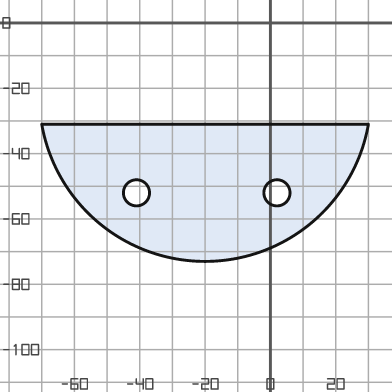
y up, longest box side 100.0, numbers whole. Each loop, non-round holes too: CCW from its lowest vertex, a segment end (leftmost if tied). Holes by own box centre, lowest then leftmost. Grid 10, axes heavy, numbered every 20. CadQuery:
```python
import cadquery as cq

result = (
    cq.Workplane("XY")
    .moveTo(-70.0, -31.0)
    .threePointArc((-20.0, -73.0), (30.0, -31.0))
    .close()
    .moveTo(-41.0, -52.0)
    .circle(4.0)
    .moveTo(2.0, -52.0)
    .circle(4.0)
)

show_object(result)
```